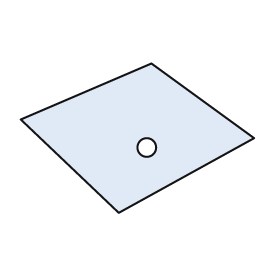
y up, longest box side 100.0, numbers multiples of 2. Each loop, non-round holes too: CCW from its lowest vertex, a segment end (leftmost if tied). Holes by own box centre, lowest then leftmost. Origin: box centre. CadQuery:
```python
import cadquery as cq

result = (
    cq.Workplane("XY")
    .moveTo(-8.0, -32.0)
    .lineTo(50.0, 0.0)
    .lineTo(6.0, 32.0)
    .lineTo(-50.0, 8.0)
    .close()
    .moveTo(4.0, -4.0)
    .circle(4.0)
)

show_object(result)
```